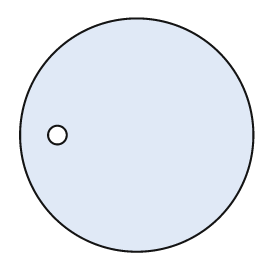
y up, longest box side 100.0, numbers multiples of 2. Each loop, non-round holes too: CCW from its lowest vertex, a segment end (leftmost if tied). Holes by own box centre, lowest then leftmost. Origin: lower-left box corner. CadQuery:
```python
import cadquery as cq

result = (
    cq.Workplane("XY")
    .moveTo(50.0, 50.0)
    .circle(50.0)
    .moveTo(16.0, 50.0)
    .circle(4.0)
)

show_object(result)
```